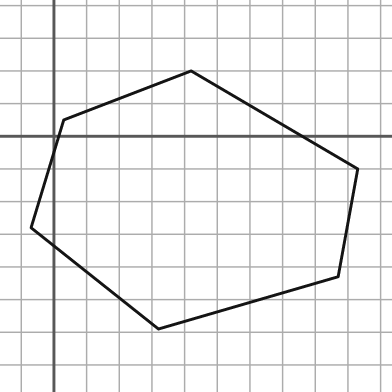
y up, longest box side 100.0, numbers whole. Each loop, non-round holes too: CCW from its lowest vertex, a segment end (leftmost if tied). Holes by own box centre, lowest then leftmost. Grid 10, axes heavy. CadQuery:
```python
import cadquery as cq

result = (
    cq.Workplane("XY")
    .moveTo(32.0, -59.0)
    .lineTo(87.0, -43.0)
    .lineTo(93.0, -10.0)
    .lineTo(42.0, 20.0)
    .lineTo(3.0, 5.0)
    .lineTo(-7.0, -28.0)
    .close()
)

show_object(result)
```